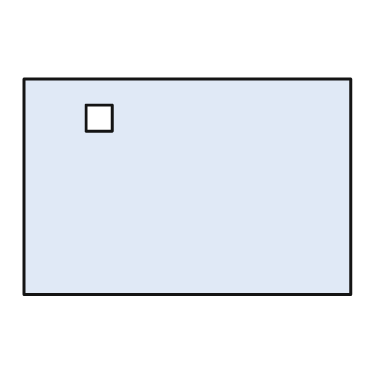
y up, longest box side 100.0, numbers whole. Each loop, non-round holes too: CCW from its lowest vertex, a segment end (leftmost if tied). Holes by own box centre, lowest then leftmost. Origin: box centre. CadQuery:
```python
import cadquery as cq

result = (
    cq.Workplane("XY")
    .moveTo(-50.0, -33.0)
    .lineTo(50.0, -33.0)
    .lineTo(50.0, 33.0)
    .lineTo(-50.0, 33.0)
    .close()
    .moveTo(-31.0, 17.0)
    .lineTo(-23.0, 17.0)
    .lineTo(-23.0, 25.0)
    .lineTo(-31.0, 25.0)
    .close()
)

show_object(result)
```